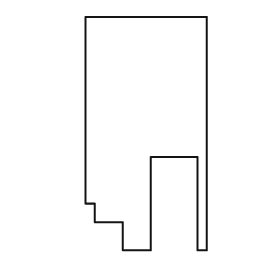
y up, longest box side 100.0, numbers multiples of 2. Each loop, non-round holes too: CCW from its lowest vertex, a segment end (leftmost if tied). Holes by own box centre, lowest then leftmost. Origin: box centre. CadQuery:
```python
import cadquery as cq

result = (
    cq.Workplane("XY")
    .moveTo(-10.0, -50.0)
    .lineTo(2.0, -50.0)
    .lineTo(2.0, -10.0)
    .lineTo(22.0, -10.0)
    .lineTo(22.0, -50.0)
    .lineTo(26.0, -50.0)
    .lineTo(26.0, 50.0)
    .lineTo(-26.0, 50.0)
    .lineTo(-26.0, -30.0)
    .lineTo(-22.0, -30.0)
    .lineTo(-22.0, -38.0)
    .lineTo(-10.0, -38.0)
    .close()
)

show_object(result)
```